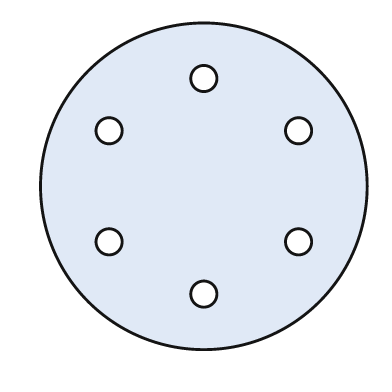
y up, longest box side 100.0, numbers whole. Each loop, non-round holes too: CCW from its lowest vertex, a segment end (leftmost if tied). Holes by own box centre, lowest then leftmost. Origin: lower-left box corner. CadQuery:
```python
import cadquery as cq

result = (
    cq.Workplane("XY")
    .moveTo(50.0, 50.0)
    .circle(50.0)
    .moveTo(50.0, 17.0)
    .circle(4.0)
    .moveTo(21.0, 33.0)
    .circle(4.0)
    .moveTo(79.0, 33.0)
    .circle(4.0)
    .moveTo(21.0, 67.0)
    .circle(4.0)
    .moveTo(79.0, 67.0)
    .circle(4.0)
    .moveTo(50.0, 83.0)
    .circle(4.0)
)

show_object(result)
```